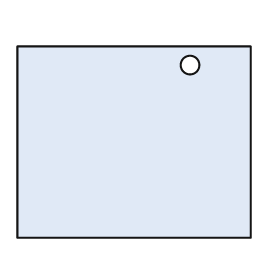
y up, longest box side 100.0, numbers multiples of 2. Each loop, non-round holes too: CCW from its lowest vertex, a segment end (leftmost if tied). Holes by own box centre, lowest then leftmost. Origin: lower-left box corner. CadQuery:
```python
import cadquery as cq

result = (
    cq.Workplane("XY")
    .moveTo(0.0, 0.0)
    .lineTo(100.0, 0.0)
    .lineTo(100.0, 82.0)
    .lineTo(0.0, 82.0)
    .close()
    .moveTo(74.0, 74.0)
    .circle(4.0)
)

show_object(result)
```